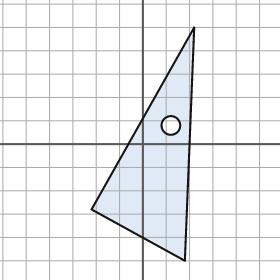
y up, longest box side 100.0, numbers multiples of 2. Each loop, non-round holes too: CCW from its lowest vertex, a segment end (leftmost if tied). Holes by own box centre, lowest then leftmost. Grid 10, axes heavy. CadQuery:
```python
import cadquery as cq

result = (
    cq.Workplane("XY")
    .moveTo(18.0, -50.0)
    .lineTo(22.0, 50.0)
    .lineTo(-22.0, -28.0)
    .close()
    .moveTo(12.0, 8.0)
    .circle(4.0)
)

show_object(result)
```